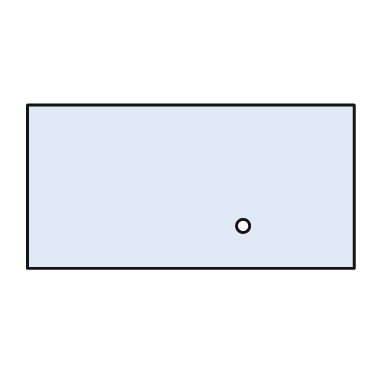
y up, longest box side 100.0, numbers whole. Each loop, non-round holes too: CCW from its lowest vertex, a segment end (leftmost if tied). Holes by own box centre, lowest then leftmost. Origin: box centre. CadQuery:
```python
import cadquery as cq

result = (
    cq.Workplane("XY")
    .moveTo(-50.0, -25.0)
    .lineTo(50.0, -25.0)
    .lineTo(50.0, 25.0)
    .lineTo(-50.0, 25.0)
    .close()
    .moveTo(16.0, -12.0)
    .circle(2.0)
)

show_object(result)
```